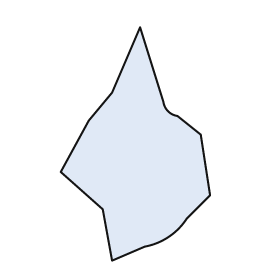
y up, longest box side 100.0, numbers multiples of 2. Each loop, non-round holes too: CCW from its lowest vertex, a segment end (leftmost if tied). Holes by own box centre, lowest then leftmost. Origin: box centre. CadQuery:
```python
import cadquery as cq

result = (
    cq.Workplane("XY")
    .moveTo(-10.0, -50.0)
    .lineTo(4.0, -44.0)
    .threePointArc((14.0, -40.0), (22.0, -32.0))
    .lineTo(32.0, -22.0)
    .lineTo(28.0, 4.0)
    .lineTo(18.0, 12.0)
    .threePointArc((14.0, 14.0), (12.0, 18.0))
    .lineTo(2.0, 50.0)
    .lineTo(-10.0, 22.0)
    .lineTo(-20.0, 10.0)
    .lineTo(-32.0, -12.0)
    .lineTo(-14.0, -28.0)
    .close()
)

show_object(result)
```